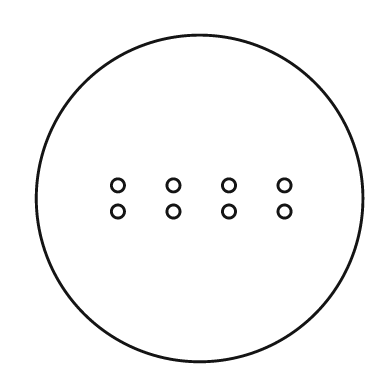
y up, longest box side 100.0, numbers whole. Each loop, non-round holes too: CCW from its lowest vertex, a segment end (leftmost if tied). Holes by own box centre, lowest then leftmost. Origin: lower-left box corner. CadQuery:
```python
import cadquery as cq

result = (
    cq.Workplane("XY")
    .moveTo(50.0, 50.0)
    .circle(50.0)
    .moveTo(25.0, 46.0)
    .circle(2.0)
    .moveTo(42.0, 46.0)
    .circle(2.0)
    .moveTo(59.0, 46.0)
    .circle(2.0)
    .moveTo(76.0, 46.0)
    .circle(2.0)
    .moveTo(25.0, 54.0)
    .circle(2.0)
    .moveTo(42.0, 54.0)
    .circle(2.0)
    .moveTo(59.0, 54.0)
    .circle(2.0)
    .moveTo(76.0, 54.0)
    .circle(2.0)
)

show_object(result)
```